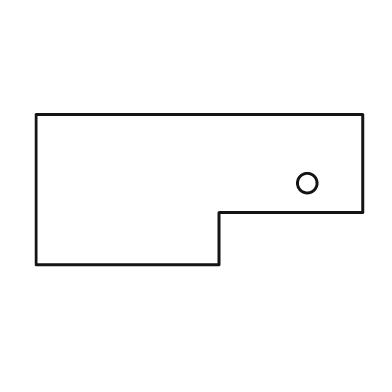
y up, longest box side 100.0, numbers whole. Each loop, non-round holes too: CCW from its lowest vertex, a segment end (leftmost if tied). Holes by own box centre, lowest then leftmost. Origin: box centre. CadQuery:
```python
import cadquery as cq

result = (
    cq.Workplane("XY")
    .moveTo(-50.0, -23.0)
    .lineTo(6.0, -23.0)
    .lineTo(6.0, -7.0)
    .lineTo(50.0, -7.0)
    .lineTo(50.0, 23.0)
    .lineTo(-50.0, 23.0)
    .close()
    .moveTo(33.0, 2.0)
    .circle(3.0)
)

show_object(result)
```